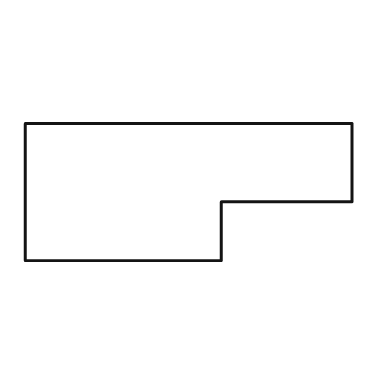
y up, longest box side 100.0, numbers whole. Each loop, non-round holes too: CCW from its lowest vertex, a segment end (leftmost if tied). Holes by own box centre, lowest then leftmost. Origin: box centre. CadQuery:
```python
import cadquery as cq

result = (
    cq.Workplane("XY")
    .moveTo(-50.0, -21.0)
    .lineTo(10.0, -21.0)
    .lineTo(10.0, -3.0)
    .lineTo(50.0, -3.0)
    .lineTo(50.0, 21.0)
    .lineTo(-50.0, 21.0)
    .close()
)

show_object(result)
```